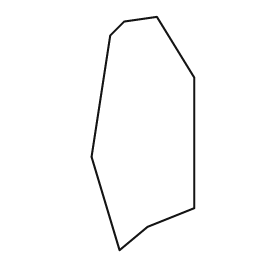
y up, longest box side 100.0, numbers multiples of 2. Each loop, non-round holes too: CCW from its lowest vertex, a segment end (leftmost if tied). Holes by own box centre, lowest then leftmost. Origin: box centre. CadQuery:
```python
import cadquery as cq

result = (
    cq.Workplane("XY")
    .moveTo(-10.0, -50.0)
    .lineTo(2.0, -40.0)
    .lineTo(22.0, -32.0)
    .lineTo(22.0, 24.0)
    .lineTo(6.0, 50.0)
    .lineTo(-8.0, 48.0)
    .lineTo(-14.0, 42.0)
    .lineTo(-22.0, -10.0)
    .close()
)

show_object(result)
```